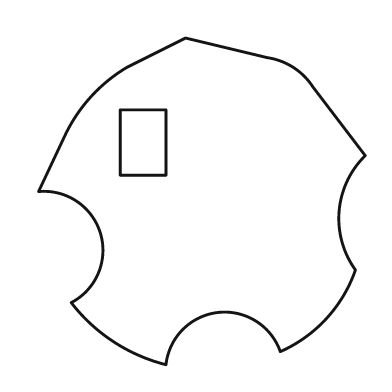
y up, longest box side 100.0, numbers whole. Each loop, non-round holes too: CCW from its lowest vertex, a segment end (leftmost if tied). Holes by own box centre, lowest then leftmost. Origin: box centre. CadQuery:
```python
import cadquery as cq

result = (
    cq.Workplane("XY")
    .moveTo(-11.0, -50.0)
    .threePointArc((5.0, -34.0), (24.0, -46.0))
    .threePointArc((38.0, -36.0), (47.0, -21.0))
    .threePointArc((42.0, -3.0), (50.0, 14.0))
    .lineTo(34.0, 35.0)
    .threePointArc((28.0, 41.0), (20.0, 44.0))
    .lineTo(-5.0, 50.0)
    .lineTo(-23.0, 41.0)
    .threePointArc((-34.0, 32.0), (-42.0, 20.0))
    .lineTo(-50.0, 3.0)
    .threePointArc((-31.0, -10.0), (-40.0, -31.0))
    .threePointArc((-27.0, -43.0), (-11.0, -50.0))
    .close()
    .moveTo(-25.0, 8.0)
    .lineTo(-11.0, 8.0)
    .lineTo(-11.0, 28.0)
    .lineTo(-25.0, 28.0)
    .close()
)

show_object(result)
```